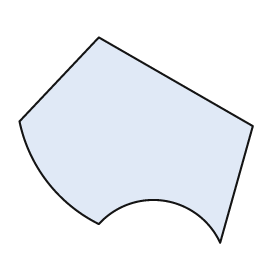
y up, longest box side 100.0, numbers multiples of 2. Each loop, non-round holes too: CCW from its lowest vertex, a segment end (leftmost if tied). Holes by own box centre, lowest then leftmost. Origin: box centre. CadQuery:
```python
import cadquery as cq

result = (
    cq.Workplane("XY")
    .moveTo(36.0, -44.0)
    .lineTo(50.0, 6.0)
    .lineTo(-16.0, 44.0)
    .lineTo(-50.0, 8.0)
    .threePointArc((-38.0, -18.0), (-16.0, -36.0))
    .threePointArc((12.0, -26.0), (36.0, -44.0))
    .close()
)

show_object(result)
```